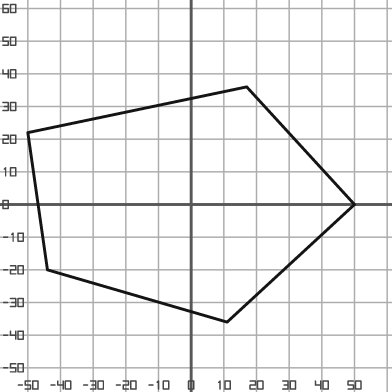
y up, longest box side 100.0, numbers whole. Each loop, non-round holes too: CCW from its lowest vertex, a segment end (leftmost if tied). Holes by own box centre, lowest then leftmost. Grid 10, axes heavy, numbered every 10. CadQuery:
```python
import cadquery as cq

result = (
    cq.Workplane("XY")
    .moveTo(11.0, -36.0)
    .lineTo(50.0, 0.0)
    .lineTo(17.0, 36.0)
    .lineTo(-50.0, 22.0)
    .lineTo(-44.0, -20.0)
    .close()
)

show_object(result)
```